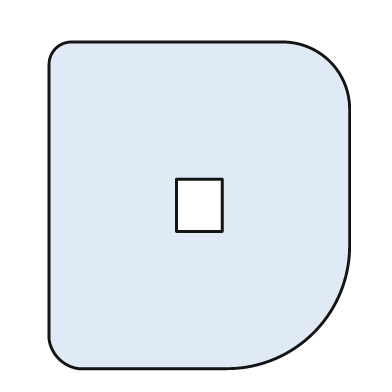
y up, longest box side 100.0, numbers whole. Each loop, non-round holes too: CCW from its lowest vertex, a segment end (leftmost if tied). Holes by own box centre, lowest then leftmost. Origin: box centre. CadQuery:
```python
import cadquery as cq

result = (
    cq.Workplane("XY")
    .moveTo(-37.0, -50.0)
    .lineTo(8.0, -50.0)
    .threePointArc((35.0, -39.0), (46.0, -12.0))
    .lineTo(46.0, 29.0)
    .threePointArc((40.0, 44.0), (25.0, 50.0))
    .lineTo(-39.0, 50.0)
    .threePointArc((-44.0, 48.0), (-46.0, 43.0))
    .lineTo(-46.0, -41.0)
    .threePointArc((-43.0, -47.0), (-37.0, -50.0))
    .close()
    .moveTo(-7.0, -8.0)
    .lineTo(7.0, -8.0)
    .lineTo(7.0, 8.0)
    .lineTo(-7.0, 8.0)
    .close()
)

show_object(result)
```